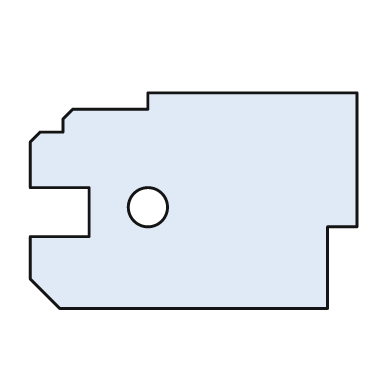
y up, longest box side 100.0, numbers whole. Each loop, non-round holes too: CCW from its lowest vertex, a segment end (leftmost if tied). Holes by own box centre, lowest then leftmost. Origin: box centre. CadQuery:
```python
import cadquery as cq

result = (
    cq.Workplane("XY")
    .moveTo(-41.0, -33.0)
    .lineTo(41.0, -33.0)
    .lineTo(41.0, -8.0)
    .lineTo(50.0, -8.0)
    .lineTo(50.0, 33.0)
    .lineTo(-14.0, 33.0)
    .lineTo(-14.0, 28.0)
    .lineTo(-37.0, 28.0)
    .lineTo(-40.0, 25.0)
    .lineTo(-40.0, 21.0)
    .lineTo(-47.0, 21.0)
    .lineTo(-50.0, 18.0)
    .lineTo(-50.0, 4.0)
    .lineTo(-32.0, 4.0)
    .lineTo(-32.0, -11.0)
    .lineTo(-50.0, -11.0)
    .lineTo(-50.0, -24.0)
    .close()
    .moveTo(-14.0, -2.0)
    .circle(6.0)
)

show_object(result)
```